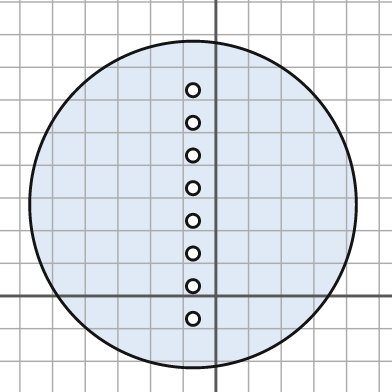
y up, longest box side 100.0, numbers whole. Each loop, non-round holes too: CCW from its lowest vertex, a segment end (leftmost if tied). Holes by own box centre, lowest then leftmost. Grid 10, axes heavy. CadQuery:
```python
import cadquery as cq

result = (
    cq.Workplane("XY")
    .moveTo(-7.0, 28.0)
    .circle(50.0)
    .moveTo(-7.0, -7.0)
    .circle(2.0)
    .moveTo(-7.0, 3.0)
    .circle(2.0)
    .moveTo(-7.0, 13.0)
    .circle(2.0)
    .moveTo(-7.0, 23.0)
    .circle(2.0)
    .moveTo(-7.0, 33.0)
    .circle(2.0)
    .moveTo(-7.0, 43.0)
    .circle(2.0)
    .moveTo(-7.0, 53.0)
    .circle(2.0)
    .moveTo(-7.0, 63.0)
    .circle(2.0)
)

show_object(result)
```